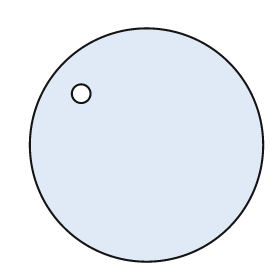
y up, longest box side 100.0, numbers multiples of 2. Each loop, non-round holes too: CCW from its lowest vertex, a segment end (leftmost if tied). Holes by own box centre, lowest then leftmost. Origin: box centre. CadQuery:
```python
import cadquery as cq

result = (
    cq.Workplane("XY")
    .moveTo(0.0, 0.0)
    .circle(50.0)
    .moveTo(-28.0, 22.0)
    .circle(4.0)
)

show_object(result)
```